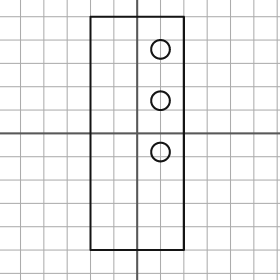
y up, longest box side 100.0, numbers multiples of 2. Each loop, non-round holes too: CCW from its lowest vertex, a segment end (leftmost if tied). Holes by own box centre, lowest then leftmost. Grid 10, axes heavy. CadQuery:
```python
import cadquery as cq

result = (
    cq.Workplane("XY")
    .moveTo(-20.0, -50.0)
    .lineTo(20.0, -50.0)
    .lineTo(20.0, 50.0)
    .lineTo(-20.0, 50.0)
    .close()
    .moveTo(10.0, -8.0)
    .circle(4.0)
    .moveTo(10.0, 14.0)
    .circle(4.0)
    .moveTo(10.0, 36.0)
    .circle(4.0)
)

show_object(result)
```